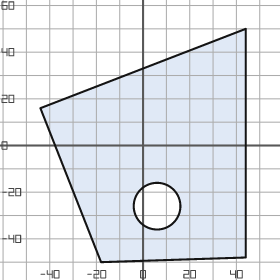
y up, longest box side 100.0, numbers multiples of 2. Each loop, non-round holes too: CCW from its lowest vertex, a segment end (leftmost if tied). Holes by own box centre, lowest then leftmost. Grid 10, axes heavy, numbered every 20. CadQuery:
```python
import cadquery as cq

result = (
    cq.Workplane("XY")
    .moveTo(-18.0, -50.0)
    .lineTo(44.0, -48.0)
    .lineTo(44.0, 50.0)
    .lineTo(-44.0, 16.0)
    .close()
    .moveTo(6.0, -26.0)
    .circle(10.0)
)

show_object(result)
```